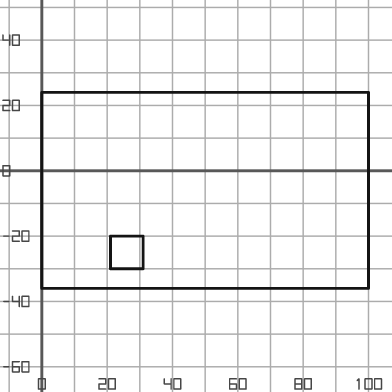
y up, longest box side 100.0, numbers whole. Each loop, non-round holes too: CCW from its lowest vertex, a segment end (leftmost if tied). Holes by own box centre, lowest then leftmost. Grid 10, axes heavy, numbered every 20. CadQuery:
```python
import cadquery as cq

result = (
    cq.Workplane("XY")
    .moveTo(0.0, -36.0)
    .lineTo(100.0, -36.0)
    .lineTo(100.0, 24.0)
    .lineTo(0.0, 24.0)
    .close()
    .moveTo(21.0, -30.0)
    .lineTo(31.0, -30.0)
    .lineTo(31.0, -20.0)
    .lineTo(21.0, -20.0)
    .close()
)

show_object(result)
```